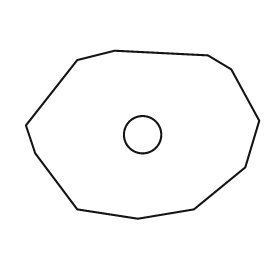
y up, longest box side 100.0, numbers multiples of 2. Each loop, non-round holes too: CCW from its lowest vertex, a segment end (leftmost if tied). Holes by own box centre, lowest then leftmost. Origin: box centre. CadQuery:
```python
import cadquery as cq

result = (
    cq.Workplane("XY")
    .moveTo(-2.0, -36.0)
    .lineTo(22.0, -32.0)
    .lineTo(44.0, -14.0)
    .lineTo(50.0, 6.0)
    .lineTo(38.0, 28.0)
    .lineTo(28.0, 34.0)
    .lineTo(-12.0, 36.0)
    .lineTo(-28.0, 32.0)
    .lineTo(-50.0, 4.0)
    .lineTo(-46.0, -8.0)
    .lineTo(-28.0, -32.0)
    .close()
    .moveTo(0.0, 0.0)
    .circle(8.0)
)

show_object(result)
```